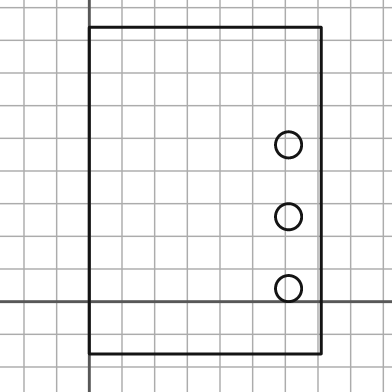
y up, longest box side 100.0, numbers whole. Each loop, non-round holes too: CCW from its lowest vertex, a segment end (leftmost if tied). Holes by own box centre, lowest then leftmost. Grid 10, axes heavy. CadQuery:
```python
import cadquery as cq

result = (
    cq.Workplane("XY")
    .moveTo(0.0, -16.0)
    .lineTo(71.0, -16.0)
    .lineTo(71.0, 84.0)
    .lineTo(0.0, 84.0)
    .close()
    .moveTo(61.0, 4.0)
    .circle(4.0)
    .moveTo(61.0, 26.0)
    .circle(4.0)
    .moveTo(61.0, 48.0)
    .circle(4.0)
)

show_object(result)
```